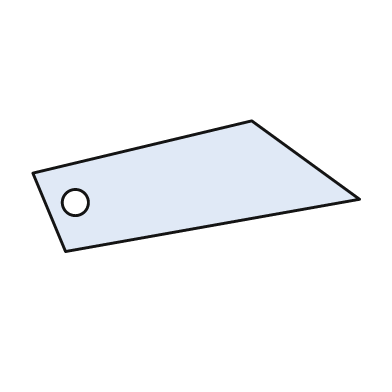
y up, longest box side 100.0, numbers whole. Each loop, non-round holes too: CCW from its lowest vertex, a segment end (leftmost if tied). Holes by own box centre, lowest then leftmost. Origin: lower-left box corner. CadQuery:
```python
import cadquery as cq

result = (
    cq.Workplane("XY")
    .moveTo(10.0, 0.0)
    .lineTo(100.0, 16.0)
    .lineTo(67.0, 40.0)
    .lineTo(0.0, 24.0)
    .close()
    .moveTo(13.0, 15.0)
    .circle(4.0)
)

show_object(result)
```